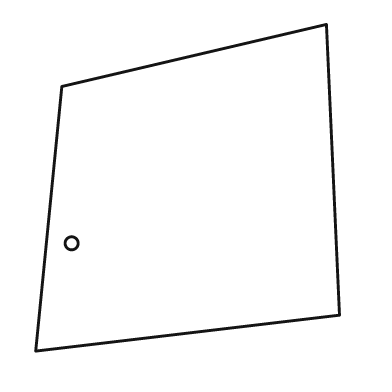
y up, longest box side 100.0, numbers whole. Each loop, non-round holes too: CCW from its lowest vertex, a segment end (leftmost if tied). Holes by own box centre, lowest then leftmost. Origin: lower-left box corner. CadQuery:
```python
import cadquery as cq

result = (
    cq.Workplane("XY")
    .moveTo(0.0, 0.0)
    .lineTo(93.0, 11.0)
    .lineTo(89.0, 100.0)
    .lineTo(8.0, 81.0)
    .close()
    .moveTo(11.0, 33.0)
    .circle(2.0)
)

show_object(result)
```